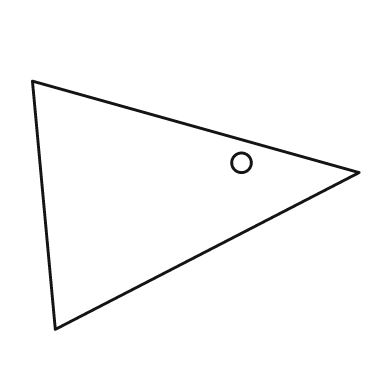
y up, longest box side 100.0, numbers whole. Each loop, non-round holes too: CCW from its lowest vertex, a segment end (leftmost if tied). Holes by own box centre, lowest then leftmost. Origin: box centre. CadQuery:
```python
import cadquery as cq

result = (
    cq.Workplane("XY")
    .moveTo(-43.0, -38.0)
    .lineTo(50.0, 10.0)
    .lineTo(-50.0, 38.0)
    .close()
    .moveTo(14.0, 13.0)
    .circle(3.0)
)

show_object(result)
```